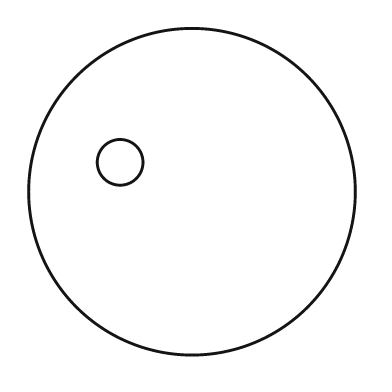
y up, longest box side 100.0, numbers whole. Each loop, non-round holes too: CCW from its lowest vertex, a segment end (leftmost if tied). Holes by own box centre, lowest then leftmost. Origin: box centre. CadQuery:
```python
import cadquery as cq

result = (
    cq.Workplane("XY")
    .moveTo(0.0, 0.0)
    .circle(50.0)
    .moveTo(-22.0, 9.0)
    .circle(7.0)
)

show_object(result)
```